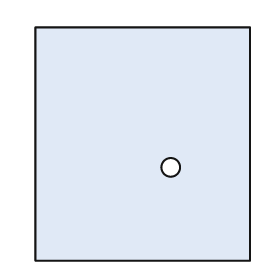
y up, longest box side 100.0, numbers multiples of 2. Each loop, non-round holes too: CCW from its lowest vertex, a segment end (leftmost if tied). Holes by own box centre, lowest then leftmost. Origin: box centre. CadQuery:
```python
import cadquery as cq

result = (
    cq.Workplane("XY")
    .moveTo(-46.0, -50.0)
    .lineTo(46.0, -50.0)
    .lineTo(46.0, 50.0)
    .lineTo(-46.0, 50.0)
    .close()
    .moveTo(12.0, -10.0)
    .circle(4.0)
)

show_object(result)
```